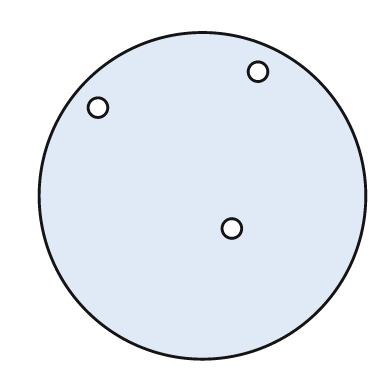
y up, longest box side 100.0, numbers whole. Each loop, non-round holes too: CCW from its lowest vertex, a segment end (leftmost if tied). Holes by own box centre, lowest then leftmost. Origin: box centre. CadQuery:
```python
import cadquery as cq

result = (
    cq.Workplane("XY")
    .moveTo(0.0, 0.0)
    .circle(50.0)
    .moveTo(9.0, -10.0)
    .circle(3.0)
    .moveTo(-32.0, 27.0)
    .circle(3.0)
    .moveTo(17.0, 38.0)
    .circle(3.0)
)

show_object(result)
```